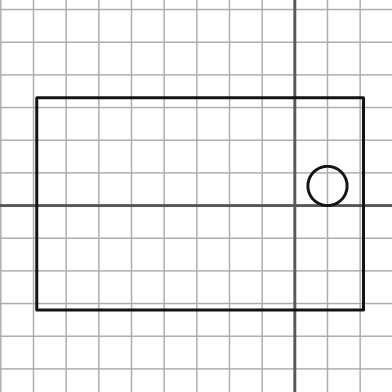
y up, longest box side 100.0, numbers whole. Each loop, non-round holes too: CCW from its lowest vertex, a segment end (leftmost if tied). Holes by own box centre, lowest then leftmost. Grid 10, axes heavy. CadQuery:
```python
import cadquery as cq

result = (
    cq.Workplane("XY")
    .moveTo(-79.0, -32.0)
    .lineTo(21.0, -32.0)
    .lineTo(21.0, 33.0)
    .lineTo(-79.0, 33.0)
    .close()
    .moveTo(10.0, 6.0)
    .circle(6.0)
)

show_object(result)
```